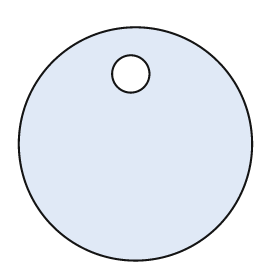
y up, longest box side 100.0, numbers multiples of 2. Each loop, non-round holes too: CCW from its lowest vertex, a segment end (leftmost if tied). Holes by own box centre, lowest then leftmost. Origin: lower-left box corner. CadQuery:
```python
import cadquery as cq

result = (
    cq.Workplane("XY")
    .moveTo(50.0, 50.0)
    .circle(50.0)
    .moveTo(48.0, 80.0)
    .circle(8.0)
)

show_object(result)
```